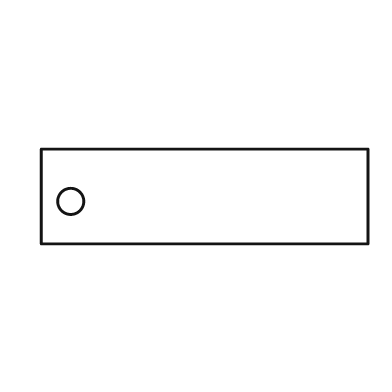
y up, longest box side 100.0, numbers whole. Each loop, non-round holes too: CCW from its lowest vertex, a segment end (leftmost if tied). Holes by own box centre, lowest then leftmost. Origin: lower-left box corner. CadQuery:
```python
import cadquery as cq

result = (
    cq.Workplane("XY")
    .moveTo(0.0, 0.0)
    .lineTo(100.0, 0.0)
    .lineTo(100.0, 29.0)
    .lineTo(0.0, 29.0)
    .close()
    .moveTo(9.0, 13.0)
    .circle(4.0)
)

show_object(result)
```